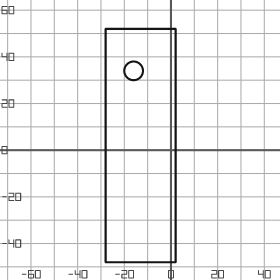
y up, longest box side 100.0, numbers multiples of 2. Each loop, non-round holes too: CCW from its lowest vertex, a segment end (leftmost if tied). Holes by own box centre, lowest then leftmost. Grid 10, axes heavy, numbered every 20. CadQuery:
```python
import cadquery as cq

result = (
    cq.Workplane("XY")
    .moveTo(-28.0, -48.0)
    .lineTo(2.0, -48.0)
    .lineTo(2.0, 52.0)
    .lineTo(-28.0, 52.0)
    .close()
    .moveTo(-16.0, 34.0)
    .circle(4.0)
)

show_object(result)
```